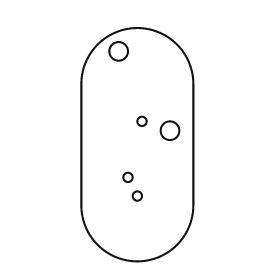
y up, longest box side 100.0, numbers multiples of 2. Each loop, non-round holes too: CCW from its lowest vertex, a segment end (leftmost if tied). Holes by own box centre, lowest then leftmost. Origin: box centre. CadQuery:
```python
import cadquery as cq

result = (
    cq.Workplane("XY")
    .moveTo(-24.0, -26.0)
    .threePointArc((0.0, -50.0), (24.0, -26.0))
    .lineTo(24.0, 26.0)
    .threePointArc((0.0, 50.0), (-24.0, 26.0))
    .close()
    .moveTo(0.0, -22.0)
    .circle(2.0)
    .moveTo(-4.0, -14.0)
    .circle(2.0)
    .moveTo(14.0, 6.0)
    .circle(4.0)
    .moveTo(2.0, 10.0)
    .circle(2.0)
    .moveTo(-8.0, 40.0)
    .circle(4.0)
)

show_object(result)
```